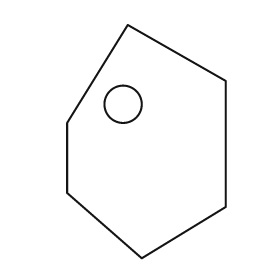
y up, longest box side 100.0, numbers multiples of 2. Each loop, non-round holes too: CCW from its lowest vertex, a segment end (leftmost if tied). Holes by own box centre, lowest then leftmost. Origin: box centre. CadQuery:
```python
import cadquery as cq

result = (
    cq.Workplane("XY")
    .moveTo(-2.0, -50.0)
    .lineTo(34.0, -28.0)
    .lineTo(34.0, 26.0)
    .lineTo(-8.0, 50.0)
    .lineTo(-34.0, 8.0)
    .lineTo(-34.0, -22.0)
    .close()
    .moveTo(-10.0, 16.0)
    .circle(8.0)
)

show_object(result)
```